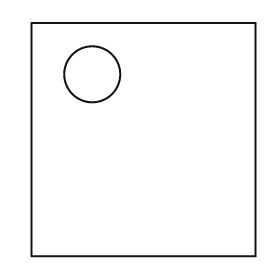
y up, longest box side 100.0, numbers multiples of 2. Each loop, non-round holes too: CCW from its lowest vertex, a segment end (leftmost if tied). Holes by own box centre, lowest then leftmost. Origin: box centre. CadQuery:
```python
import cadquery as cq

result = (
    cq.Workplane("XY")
    .moveTo(-48.0, -50.0)
    .lineTo(48.0, -50.0)
    .lineTo(48.0, 50.0)
    .lineTo(-48.0, 50.0)
    .close()
    .moveTo(-22.0, 28.0)
    .circle(12.0)
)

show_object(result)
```